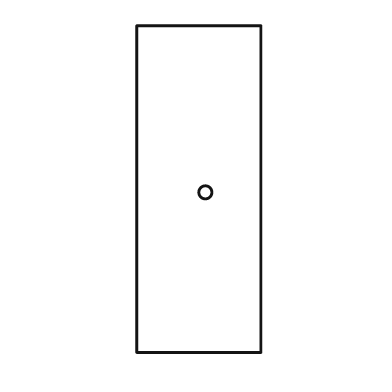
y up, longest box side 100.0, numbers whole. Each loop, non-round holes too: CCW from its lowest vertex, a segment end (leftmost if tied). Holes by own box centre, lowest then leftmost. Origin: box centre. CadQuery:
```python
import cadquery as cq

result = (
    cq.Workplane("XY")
    .moveTo(-19.0, -50.0)
    .lineTo(19.0, -50.0)
    .lineTo(19.0, 50.0)
    .lineTo(-19.0, 50.0)
    .close()
    .moveTo(2.0, -1.0)
    .circle(2.0)
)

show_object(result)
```